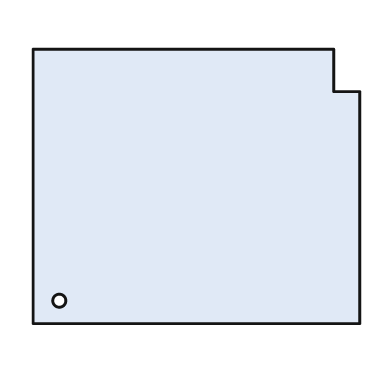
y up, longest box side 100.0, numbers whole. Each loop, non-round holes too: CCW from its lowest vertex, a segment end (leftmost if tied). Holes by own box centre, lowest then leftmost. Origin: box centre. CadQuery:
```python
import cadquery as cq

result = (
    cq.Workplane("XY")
    .moveTo(-50.0, -42.0)
    .lineTo(50.0, -42.0)
    .lineTo(50.0, 29.0)
    .lineTo(42.0, 29.0)
    .lineTo(42.0, 42.0)
    .lineTo(-50.0, 42.0)
    .close()
    .moveTo(-42.0, -35.0)
    .circle(2.0)
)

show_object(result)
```